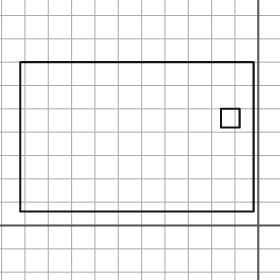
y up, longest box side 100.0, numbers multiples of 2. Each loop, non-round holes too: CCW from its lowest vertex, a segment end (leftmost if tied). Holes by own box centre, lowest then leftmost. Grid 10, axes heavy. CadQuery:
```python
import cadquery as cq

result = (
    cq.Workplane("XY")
    .moveTo(-102.0, 6.0)
    .lineTo(-2.0, 6.0)
    .lineTo(-2.0, 70.0)
    .lineTo(-102.0, 70.0)
    .close()
    .moveTo(-16.0, 42.0)
    .lineTo(-8.0, 42.0)
    .lineTo(-8.0, 50.0)
    .lineTo(-16.0, 50.0)
    .close()
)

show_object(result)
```